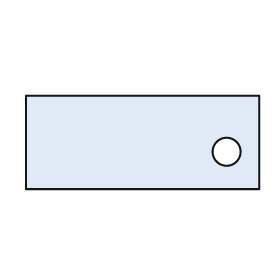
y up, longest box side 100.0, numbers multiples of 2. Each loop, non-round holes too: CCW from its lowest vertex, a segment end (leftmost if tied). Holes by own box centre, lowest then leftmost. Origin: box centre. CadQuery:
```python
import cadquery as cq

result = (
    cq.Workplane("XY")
    .moveTo(-50.0, -20.0)
    .lineTo(50.0, -20.0)
    .lineTo(50.0, 20.0)
    .lineTo(-50.0, 20.0)
    .close()
    .moveTo(36.0, -4.0)
    .circle(6.0)
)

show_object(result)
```